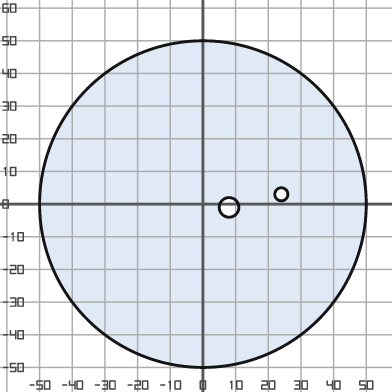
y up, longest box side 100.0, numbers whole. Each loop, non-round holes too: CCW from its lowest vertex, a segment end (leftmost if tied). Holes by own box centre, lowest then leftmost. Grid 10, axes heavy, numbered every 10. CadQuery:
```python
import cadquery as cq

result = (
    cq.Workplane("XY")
    .moveTo(0.0, 0.0)
    .circle(50.0)
    .moveTo(8.0, -1.0)
    .circle(3.0)
    .moveTo(24.0, 3.0)
    .circle(2.0)
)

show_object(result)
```